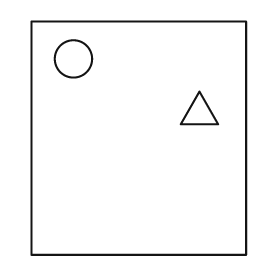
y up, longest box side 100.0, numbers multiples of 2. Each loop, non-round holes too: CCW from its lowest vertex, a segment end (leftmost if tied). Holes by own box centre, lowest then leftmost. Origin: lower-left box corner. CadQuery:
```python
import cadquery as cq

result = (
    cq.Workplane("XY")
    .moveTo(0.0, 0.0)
    .lineTo(92.0, 0.0)
    .lineTo(92.0, 100.0)
    .lineTo(0.0, 100.0)
    .close()
    .moveTo(64.0, 56.0)
    .lineTo(80.0, 56.0)
    .lineTo(72.0, 70.0)
    .close()
    .moveTo(18.0, 84.0)
    .circle(8.0)
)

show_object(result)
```